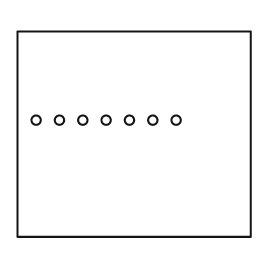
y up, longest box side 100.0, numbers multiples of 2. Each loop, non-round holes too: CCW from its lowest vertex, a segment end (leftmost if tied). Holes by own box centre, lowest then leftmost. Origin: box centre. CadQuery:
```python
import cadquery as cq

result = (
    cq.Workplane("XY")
    .moveTo(-50.0, -44.0)
    .lineTo(50.0, -44.0)
    .lineTo(50.0, 44.0)
    .lineTo(-50.0, 44.0)
    .close()
    .moveTo(-42.0, 6.0)
    .circle(2.0)
    .moveTo(-32.0, 6.0)
    .circle(2.0)
    .moveTo(-22.0, 6.0)
    .circle(2.0)
    .moveTo(-12.0, 6.0)
    .circle(2.0)
    .moveTo(-2.0, 6.0)
    .circle(2.0)
    .moveTo(8.0, 6.0)
    .circle(2.0)
    .moveTo(18.0, 6.0)
    .circle(2.0)
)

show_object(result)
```